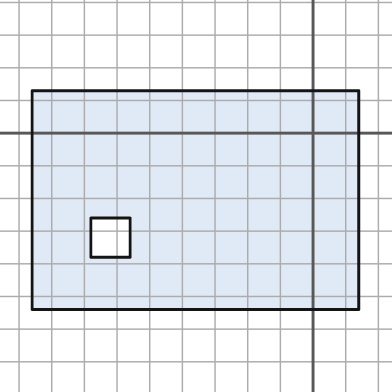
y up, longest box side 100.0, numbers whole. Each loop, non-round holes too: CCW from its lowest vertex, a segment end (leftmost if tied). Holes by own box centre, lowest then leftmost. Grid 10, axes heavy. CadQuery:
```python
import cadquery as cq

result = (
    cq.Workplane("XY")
    .moveTo(-86.0, -54.0)
    .lineTo(14.0, -54.0)
    .lineTo(14.0, 13.0)
    .lineTo(-86.0, 13.0)
    .close()
    .moveTo(-68.0, -38.0)
    .lineTo(-56.0, -38.0)
    .lineTo(-56.0, -26.0)
    .lineTo(-68.0, -26.0)
    .close()
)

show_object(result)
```